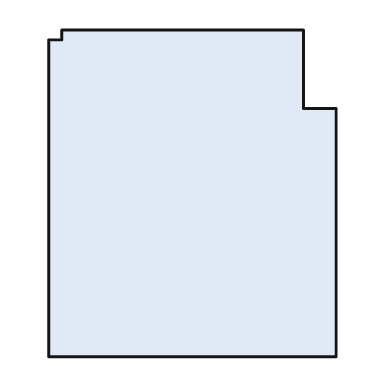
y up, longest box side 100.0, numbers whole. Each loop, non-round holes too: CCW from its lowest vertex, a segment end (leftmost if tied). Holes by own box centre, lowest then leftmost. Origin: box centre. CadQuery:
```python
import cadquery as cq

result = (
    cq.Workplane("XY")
    .moveTo(-44.0, -50.0)
    .lineTo(44.0, -50.0)
    .lineTo(44.0, 26.0)
    .lineTo(34.0, 26.0)
    .lineTo(34.0, 50.0)
    .lineTo(-40.0, 50.0)
    .lineTo(-40.0, 47.0)
    .lineTo(-44.0, 47.0)
    .close()
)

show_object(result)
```